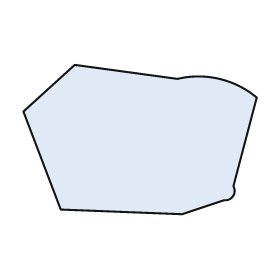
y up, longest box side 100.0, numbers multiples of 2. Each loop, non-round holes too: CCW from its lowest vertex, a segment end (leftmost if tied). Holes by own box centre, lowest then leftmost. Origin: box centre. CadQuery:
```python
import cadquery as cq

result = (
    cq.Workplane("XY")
    .moveTo(18.0, -32.0)
    .lineTo(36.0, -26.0)
    .threePointArc((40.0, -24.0), (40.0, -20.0))
    .lineTo(50.0, 18.0)
    .threePointArc((34.0, 26.0), (16.0, 26.0))
    .lineTo(-28.0, 32.0)
    .lineTo(-50.0, 12.0)
    .lineTo(-34.0, -30.0)
    .close()
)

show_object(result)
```